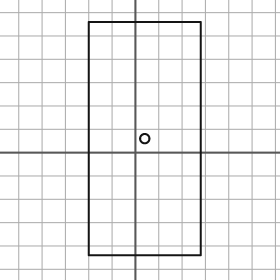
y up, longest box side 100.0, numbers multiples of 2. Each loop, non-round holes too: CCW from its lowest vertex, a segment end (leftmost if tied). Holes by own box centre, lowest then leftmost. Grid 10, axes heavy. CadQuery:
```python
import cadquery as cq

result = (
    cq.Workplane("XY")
    .moveTo(-20.0, -44.0)
    .lineTo(28.0, -44.0)
    .lineTo(28.0, 56.0)
    .lineTo(-20.0, 56.0)
    .close()
    .moveTo(4.0, 6.0)
    .circle(2.0)
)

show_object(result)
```